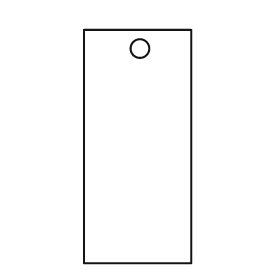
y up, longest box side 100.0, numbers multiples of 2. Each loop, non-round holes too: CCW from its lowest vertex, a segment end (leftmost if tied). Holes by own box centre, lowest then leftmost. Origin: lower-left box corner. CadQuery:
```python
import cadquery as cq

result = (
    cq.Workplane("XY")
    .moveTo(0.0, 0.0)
    .lineTo(46.0, 0.0)
    .lineTo(46.0, 100.0)
    .lineTo(0.0, 100.0)
    .close()
    .moveTo(24.0, 92.0)
    .circle(4.0)
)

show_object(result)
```